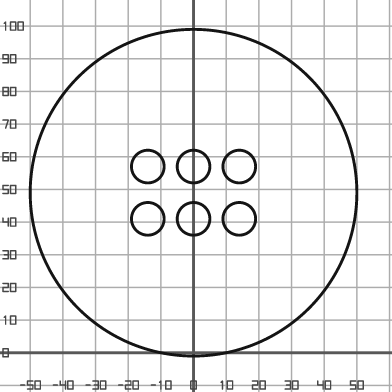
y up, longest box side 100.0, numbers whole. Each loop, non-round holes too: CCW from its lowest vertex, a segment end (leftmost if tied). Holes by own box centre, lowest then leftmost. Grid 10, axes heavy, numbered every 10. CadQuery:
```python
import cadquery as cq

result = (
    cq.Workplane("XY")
    .moveTo(0.0, 49.0)
    .circle(50.0)
    .moveTo(-14.0, 41.0)
    .circle(5.0)
    .moveTo(0.0, 41.0)
    .circle(5.0)
    .moveTo(14.0, 41.0)
    .circle(5.0)
    .moveTo(-14.0, 57.0)
    .circle(5.0)
    .moveTo(0.0, 57.0)
    .circle(5.0)
    .moveTo(14.0, 57.0)
    .circle(5.0)
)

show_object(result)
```